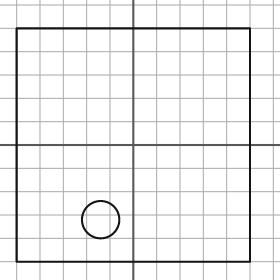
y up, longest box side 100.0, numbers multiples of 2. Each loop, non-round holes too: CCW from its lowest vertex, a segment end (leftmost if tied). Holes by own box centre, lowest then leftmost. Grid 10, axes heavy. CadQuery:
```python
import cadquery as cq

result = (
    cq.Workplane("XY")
    .moveTo(-50.0, -50.0)
    .lineTo(50.0, -50.0)
    .lineTo(50.0, 50.0)
    .lineTo(-50.0, 50.0)
    .close()
    .moveTo(-14.0, -32.0)
    .circle(8.0)
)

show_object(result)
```